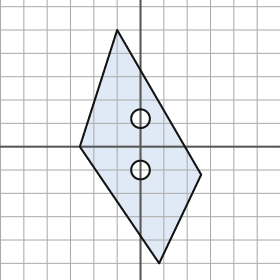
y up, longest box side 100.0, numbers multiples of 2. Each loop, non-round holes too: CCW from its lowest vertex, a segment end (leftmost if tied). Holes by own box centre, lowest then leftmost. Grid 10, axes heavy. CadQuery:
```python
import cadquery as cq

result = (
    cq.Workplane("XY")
    .moveTo(8.0, -50.0)
    .lineTo(26.0, -12.0)
    .lineTo(-10.0, 50.0)
    .lineTo(-26.0, 0.0)
    .close()
    .moveTo(0.0, -10.0)
    .circle(4.0)
    .moveTo(0.0, 12.0)
    .circle(4.0)
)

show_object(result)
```